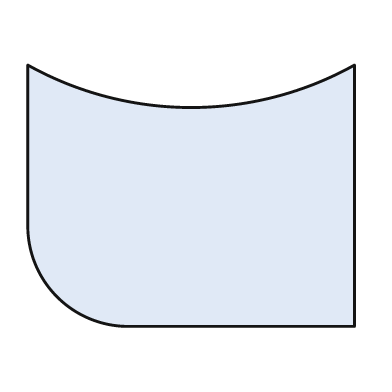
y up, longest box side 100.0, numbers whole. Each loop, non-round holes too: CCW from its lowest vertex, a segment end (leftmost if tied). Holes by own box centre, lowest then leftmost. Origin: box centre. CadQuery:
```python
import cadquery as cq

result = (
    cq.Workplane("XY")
    .moveTo(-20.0, -40.0)
    .lineTo(50.0, -40.0)
    .lineTo(50.0, 40.0)
    .threePointArc((0.0, 27.0), (-50.0, 40.0))
    .lineTo(-50.0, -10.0)
    .threePointArc((-41.0, -31.0), (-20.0, -40.0))
    .close()
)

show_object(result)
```